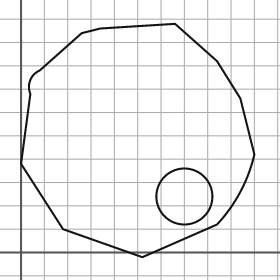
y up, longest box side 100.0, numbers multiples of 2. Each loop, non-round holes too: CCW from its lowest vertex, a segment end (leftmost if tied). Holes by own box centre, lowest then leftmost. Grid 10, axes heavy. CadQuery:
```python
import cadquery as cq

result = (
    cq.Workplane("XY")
    .moveTo(52.0, -2.0)
    .lineTo(84.0, 12.0)
    .threePointArc((94.0, 26.0), (100.0, 42.0))
    .lineTo(94.0, 66.0)
    .lineTo(84.0, 82.0)
    .lineTo(66.0, 98.0)
    .lineTo(34.0, 96.0)
    .lineTo(26.0, 94.0)
    .lineTo(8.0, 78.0)
    .threePointArc((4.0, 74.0), (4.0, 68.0))
    .lineTo(0.0, 38.0)
    .lineTo(18.0, 10.0)
    .close()
    .moveTo(70.0, 24.0)
    .circle(12.0)
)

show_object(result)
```